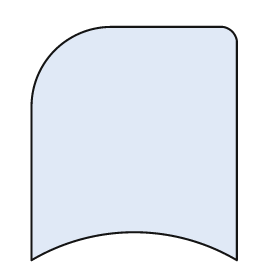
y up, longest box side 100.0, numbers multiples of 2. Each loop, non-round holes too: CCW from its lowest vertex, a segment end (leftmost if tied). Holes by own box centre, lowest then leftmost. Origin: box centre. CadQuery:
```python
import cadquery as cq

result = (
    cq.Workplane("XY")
    .moveTo(-44.0, -50.0)
    .threePointArc((0.0, -38.0), (44.0, -50.0))
    .lineTo(44.0, 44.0)
    .threePointArc((42.0, 48.0), (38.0, 50.0))
    .lineTo(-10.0, 50.0)
    .threePointArc((-34.0, 40.0), (-44.0, 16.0))
    .close()
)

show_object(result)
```